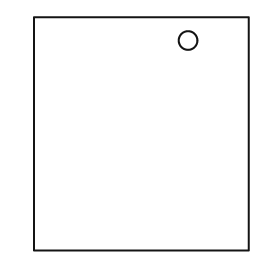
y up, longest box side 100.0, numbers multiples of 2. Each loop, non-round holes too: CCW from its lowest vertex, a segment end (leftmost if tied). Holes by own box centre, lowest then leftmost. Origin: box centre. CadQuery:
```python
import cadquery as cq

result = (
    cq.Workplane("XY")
    .moveTo(-46.0, -50.0)
    .lineTo(46.0, -50.0)
    .lineTo(46.0, 50.0)
    .lineTo(-46.0, 50.0)
    .close()
    .moveTo(20.0, 40.0)
    .circle(4.0)
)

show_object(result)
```